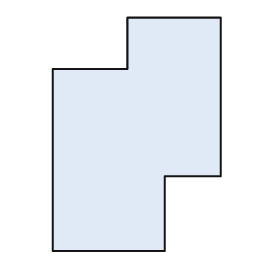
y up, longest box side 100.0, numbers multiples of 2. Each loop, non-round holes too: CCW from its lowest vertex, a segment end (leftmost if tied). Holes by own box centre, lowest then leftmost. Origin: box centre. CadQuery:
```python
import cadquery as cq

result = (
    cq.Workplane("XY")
    .moveTo(-36.0, -50.0)
    .lineTo(12.0, -50.0)
    .lineTo(12.0, -18.0)
    .lineTo(36.0, -18.0)
    .lineTo(36.0, 50.0)
    .lineTo(-4.0, 50.0)
    .lineTo(-4.0, 28.0)
    .lineTo(-36.0, 28.0)
    .close()
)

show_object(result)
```